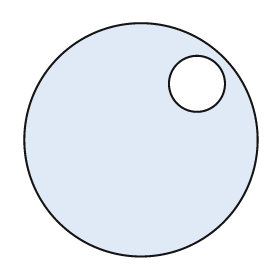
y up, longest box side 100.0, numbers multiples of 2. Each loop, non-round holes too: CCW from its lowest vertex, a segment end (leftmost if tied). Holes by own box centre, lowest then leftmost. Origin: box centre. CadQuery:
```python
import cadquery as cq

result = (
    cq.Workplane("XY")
    .moveTo(0.0, 0.0)
    .circle(50.0)
    .moveTo(24.0, 24.0)
    .circle(12.0)
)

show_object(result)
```